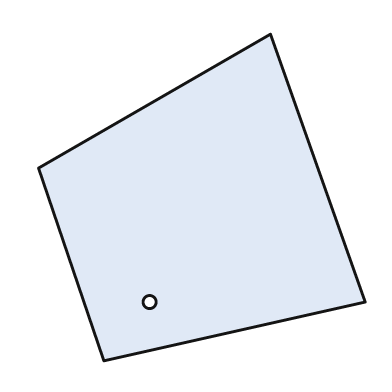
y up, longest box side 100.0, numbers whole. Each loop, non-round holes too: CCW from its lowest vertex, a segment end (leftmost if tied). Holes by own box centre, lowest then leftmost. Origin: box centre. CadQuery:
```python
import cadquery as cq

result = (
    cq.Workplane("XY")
    .moveTo(-30.0, -50.0)
    .lineTo(50.0, -32.0)
    .lineTo(21.0, 50.0)
    .lineTo(-50.0, 9.0)
    .close()
    .moveTo(-16.0, -32.0)
    .circle(2.0)
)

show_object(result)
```